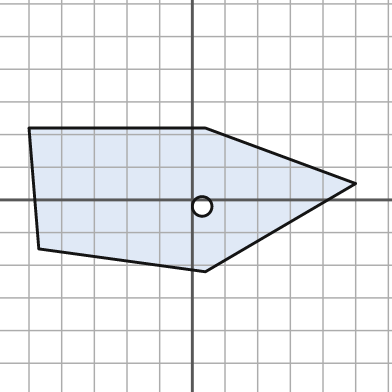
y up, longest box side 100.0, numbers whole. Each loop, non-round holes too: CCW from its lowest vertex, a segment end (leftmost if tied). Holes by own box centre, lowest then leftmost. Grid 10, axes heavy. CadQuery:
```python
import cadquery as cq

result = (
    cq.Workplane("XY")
    .moveTo(4.0, -22.0)
    .lineTo(50.0, 5.0)
    .lineTo(4.0, 22.0)
    .lineTo(-50.0, 22.0)
    .lineTo(-47.0, -15.0)
    .close()
    .moveTo(3.0, -2.0)
    .circle(3.0)
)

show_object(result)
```